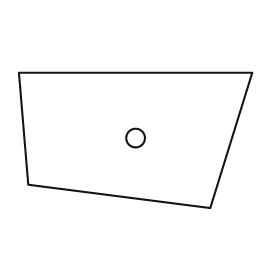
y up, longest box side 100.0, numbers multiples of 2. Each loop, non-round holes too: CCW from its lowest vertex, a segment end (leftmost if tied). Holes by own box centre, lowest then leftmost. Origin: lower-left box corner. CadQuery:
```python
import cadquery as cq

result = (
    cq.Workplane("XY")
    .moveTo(82.0, 0.0)
    .lineTo(100.0, 58.0)
    .lineTo(0.0, 58.0)
    .lineTo(4.0, 10.0)
    .close()
    .moveTo(50.0, 30.0)
    .circle(4.0)
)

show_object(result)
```